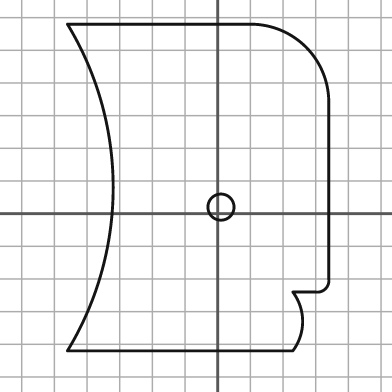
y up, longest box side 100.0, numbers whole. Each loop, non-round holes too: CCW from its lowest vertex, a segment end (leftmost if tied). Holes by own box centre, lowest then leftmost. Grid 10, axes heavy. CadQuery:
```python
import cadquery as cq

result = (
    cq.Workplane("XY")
    .moveTo(-46.0, -42.0)
    .lineTo(23.0, -42.0)
    .threePointArc((26.0, -33.0), (23.0, -24.0))
    .lineTo(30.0, -24.0)
    .threePointArc((33.0, -23.0), (34.0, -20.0))
    .lineTo(34.0, 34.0)
    .threePointArc((27.0, 51.0), (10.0, 58.0))
    .lineTo(-46.0, 58.0)
    .threePointArc((-32.0, 8.0), (-46.0, -42.0))
    .close()
    .moveTo(1.0, 2.0)
    .circle(4.0)
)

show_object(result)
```